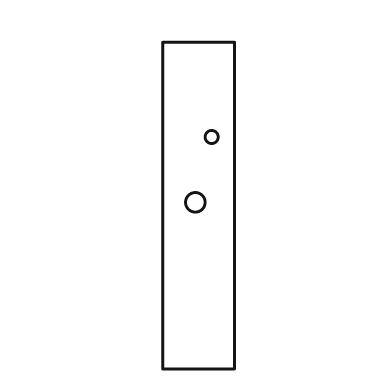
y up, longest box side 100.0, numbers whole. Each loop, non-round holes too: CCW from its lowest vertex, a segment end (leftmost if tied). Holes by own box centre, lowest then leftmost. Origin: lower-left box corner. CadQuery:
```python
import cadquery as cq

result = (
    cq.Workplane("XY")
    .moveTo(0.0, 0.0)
    .lineTo(22.0, 0.0)
    .lineTo(22.0, 100.0)
    .lineTo(0.0, 100.0)
    .close()
    .moveTo(10.0, 51.0)
    .circle(3.0)
    .moveTo(15.0, 71.0)
    .circle(2.0)
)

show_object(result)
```